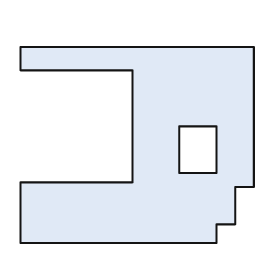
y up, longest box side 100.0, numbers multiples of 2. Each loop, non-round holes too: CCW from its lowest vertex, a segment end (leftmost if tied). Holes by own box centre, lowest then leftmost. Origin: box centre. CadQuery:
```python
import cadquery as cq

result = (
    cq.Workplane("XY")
    .moveTo(-50.0, -42.0)
    .lineTo(34.0, -42.0)
    .lineTo(34.0, -34.0)
    .lineTo(42.0, -34.0)
    .lineTo(42.0, -18.0)
    .lineTo(50.0, -18.0)
    .lineTo(50.0, 42.0)
    .lineTo(-50.0, 42.0)
    .lineTo(-50.0, 32.0)
    .lineTo(-2.0, 32.0)
    .lineTo(-2.0, -16.0)
    .lineTo(-50.0, -16.0)
    .close()
    .moveTo(18.0, -12.0)
    .lineTo(34.0, -12.0)
    .lineTo(34.0, 8.0)
    .lineTo(18.0, 8.0)
    .close()
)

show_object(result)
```